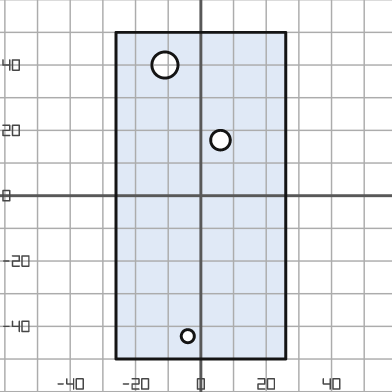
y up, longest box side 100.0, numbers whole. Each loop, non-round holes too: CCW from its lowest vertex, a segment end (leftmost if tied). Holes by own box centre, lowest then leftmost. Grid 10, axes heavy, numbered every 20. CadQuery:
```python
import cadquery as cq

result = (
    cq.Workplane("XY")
    .moveTo(-26.0, -50.0)
    .lineTo(26.0, -50.0)
    .lineTo(26.0, 50.0)
    .lineTo(-26.0, 50.0)
    .close()
    .moveTo(-4.0, -43.0)
    .circle(2.0)
    .moveTo(6.0, 17.0)
    .circle(3.0)
    .moveTo(-11.0, 40.0)
    .circle(4.0)
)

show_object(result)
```